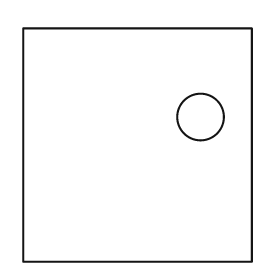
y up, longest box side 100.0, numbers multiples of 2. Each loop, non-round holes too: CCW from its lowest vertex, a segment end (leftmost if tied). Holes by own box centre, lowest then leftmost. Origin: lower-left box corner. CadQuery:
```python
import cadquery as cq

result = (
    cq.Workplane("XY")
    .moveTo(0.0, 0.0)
    .lineTo(98.0, 0.0)
    .lineTo(98.0, 100.0)
    .lineTo(0.0, 100.0)
    .close()
    .moveTo(76.0, 62.0)
    .circle(10.0)
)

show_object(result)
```